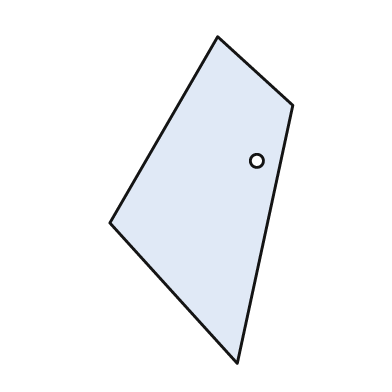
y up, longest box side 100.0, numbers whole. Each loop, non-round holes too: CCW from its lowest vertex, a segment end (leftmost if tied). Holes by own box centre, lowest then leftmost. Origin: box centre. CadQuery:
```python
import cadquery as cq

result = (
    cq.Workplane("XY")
    .moveTo(11.0, -50.0)
    .lineTo(28.0, 29.0)
    .lineTo(5.0, 50.0)
    .lineTo(-28.0, -7.0)
    .close()
    .moveTo(17.0, 12.0)
    .circle(2.0)
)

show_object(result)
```